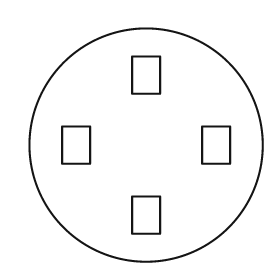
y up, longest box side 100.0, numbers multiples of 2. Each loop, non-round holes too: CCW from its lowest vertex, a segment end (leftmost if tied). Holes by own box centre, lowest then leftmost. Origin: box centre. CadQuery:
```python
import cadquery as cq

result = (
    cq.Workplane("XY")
    .moveTo(0.0, 0.0)
    .circle(50.0)
    .moveTo(-6.0, -38.0)
    .lineTo(6.0, -38.0)
    .lineTo(6.0, -22.0)
    .lineTo(-6.0, -22.0)
    .close()
    .moveTo(-36.0, -8.0)
    .lineTo(-24.0, -8.0)
    .lineTo(-24.0, 8.0)
    .lineTo(-36.0, 8.0)
    .close()
    .moveTo(24.0, -8.0)
    .lineTo(36.0, -8.0)
    .lineTo(36.0, 8.0)
    .lineTo(24.0, 8.0)
    .close()
    .moveTo(-6.0, 22.0)
    .lineTo(6.0, 22.0)
    .lineTo(6.0, 38.0)
    .lineTo(-6.0, 38.0)
    .close()
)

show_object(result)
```